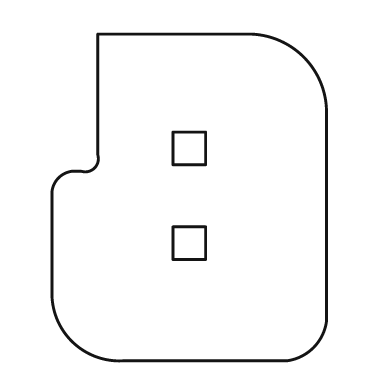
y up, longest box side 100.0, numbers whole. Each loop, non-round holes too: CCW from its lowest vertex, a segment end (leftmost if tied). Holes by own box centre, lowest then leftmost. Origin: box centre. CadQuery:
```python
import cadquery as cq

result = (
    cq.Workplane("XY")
    .moveTo(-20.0, -50.0)
    .lineTo(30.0, -50.0)
    .threePointArc((38.0, -46.0), (42.0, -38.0))
    .lineTo(42.0, 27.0)
    .threePointArc((35.0, 43.0), (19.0, 50.0))
    .lineTo(-28.0, 50.0)
    .lineTo(-28.0, 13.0)
    .threePointArc((-29.0, 9.0), (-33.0, 8.0))
    .lineTo(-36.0, 8.0)
    .threePointArc((-40.0, 6.0), (-42.0, 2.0))
    .lineTo(-42.0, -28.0)
    .threePointArc((-36.0, -44.0), (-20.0, -50.0))
    .close()
    .moveTo(-5.0, -19.0)
    .lineTo(5.0, -19.0)
    .lineTo(5.0, -9.0)
    .lineTo(-5.0, -9.0)
    .close()
    .moveTo(-5.0, 10.0)
    .lineTo(5.0, 10.0)
    .lineTo(5.0, 20.0)
    .lineTo(-5.0, 20.0)
    .close()
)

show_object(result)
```